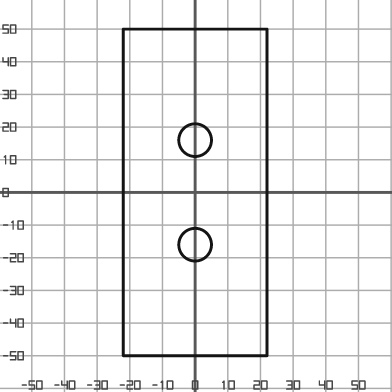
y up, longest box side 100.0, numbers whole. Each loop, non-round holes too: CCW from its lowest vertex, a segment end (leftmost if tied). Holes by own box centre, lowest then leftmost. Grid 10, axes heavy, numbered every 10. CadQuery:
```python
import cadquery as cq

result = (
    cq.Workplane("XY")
    .moveTo(-22.0, -50.0)
    .lineTo(22.0, -50.0)
    .lineTo(22.0, 50.0)
    .lineTo(-22.0, 50.0)
    .close()
    .moveTo(0.0, -16.0)
    .circle(5.0)
    .moveTo(0.0, 16.0)
    .circle(5.0)
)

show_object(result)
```